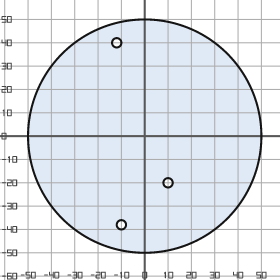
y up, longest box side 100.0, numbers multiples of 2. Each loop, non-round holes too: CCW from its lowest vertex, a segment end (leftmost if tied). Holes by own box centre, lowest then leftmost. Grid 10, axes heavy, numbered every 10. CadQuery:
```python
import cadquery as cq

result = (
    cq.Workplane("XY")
    .moveTo(0.0, 0.0)
    .circle(50.0)
    .moveTo(-10.0, -38.0)
    .circle(2.0)
    .moveTo(10.0, -20.0)
    .circle(2.0)
    .moveTo(-12.0, 40.0)
    .circle(2.0)
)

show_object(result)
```